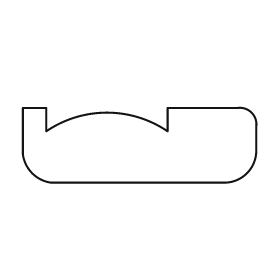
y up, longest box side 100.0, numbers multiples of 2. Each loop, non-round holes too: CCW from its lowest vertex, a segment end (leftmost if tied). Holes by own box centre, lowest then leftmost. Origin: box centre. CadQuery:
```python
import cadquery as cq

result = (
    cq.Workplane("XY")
    .moveTo(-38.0, -16.0)
    .lineTo(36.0, -16.0)
    .threePointArc((46.0, -12.0), (50.0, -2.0))
    .lineTo(50.0, 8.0)
    .threePointArc((48.0, 14.0), (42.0, 16.0))
    .lineTo(12.0, 16.0)
    .lineTo(12.0, 6.0)
    .threePointArc((-14.0, 14.0), (-40.0, 6.0))
    .lineTo(-40.0, 16.0)
    .lineTo(-50.0, 16.0)
    .lineTo(-50.0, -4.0)
    .threePointArc((-46.0, -12.0), (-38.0, -16.0))
    .close()
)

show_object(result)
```